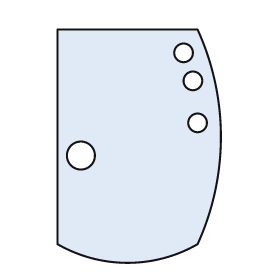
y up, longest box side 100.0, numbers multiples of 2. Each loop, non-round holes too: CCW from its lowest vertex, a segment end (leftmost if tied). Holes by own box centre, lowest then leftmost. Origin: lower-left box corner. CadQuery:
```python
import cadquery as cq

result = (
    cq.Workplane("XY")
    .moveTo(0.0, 8.0)
    .threePointArc((30.0, 0.0), (60.0, 8.0))
    .threePointArc((70.0, 54.0), (60.0, 100.0))
    .lineTo(0.0, 100.0)
    .close()
    .moveTo(10.0, 46.0)
    .circle(6.0)
    .moveTo(60.0, 60.0)
    .circle(4.0)
    .moveTo(58.0, 78.0)
    .circle(4.0)
    .moveTo(54.0, 90.0)
    .circle(4.0)
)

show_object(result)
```